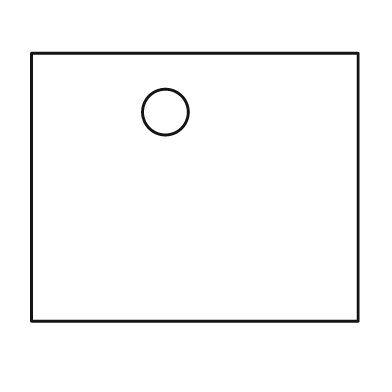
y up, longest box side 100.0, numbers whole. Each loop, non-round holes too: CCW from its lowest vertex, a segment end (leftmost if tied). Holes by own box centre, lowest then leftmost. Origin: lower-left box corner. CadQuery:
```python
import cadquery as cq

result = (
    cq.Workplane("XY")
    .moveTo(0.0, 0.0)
    .lineTo(100.0, 0.0)
    .lineTo(100.0, 82.0)
    .lineTo(0.0, 82.0)
    .close()
    .moveTo(41.0, 64.0)
    .circle(7.0)
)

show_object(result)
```